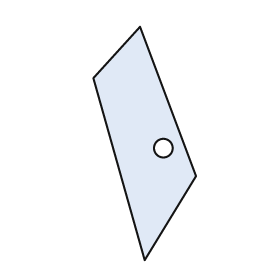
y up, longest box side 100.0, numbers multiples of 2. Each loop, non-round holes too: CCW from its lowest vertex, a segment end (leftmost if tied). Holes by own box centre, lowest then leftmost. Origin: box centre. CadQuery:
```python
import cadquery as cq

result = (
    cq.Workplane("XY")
    .moveTo(0.0, -50.0)
    .lineTo(22.0, -14.0)
    .lineTo(-2.0, 50.0)
    .lineTo(-22.0, 28.0)
    .close()
    .moveTo(8.0, -2.0)
    .circle(4.0)
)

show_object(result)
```